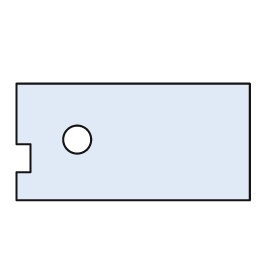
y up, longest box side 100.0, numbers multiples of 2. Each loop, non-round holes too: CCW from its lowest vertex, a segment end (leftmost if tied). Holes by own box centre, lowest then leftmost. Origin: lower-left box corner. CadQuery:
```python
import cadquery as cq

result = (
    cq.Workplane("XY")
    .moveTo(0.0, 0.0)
    .lineTo(100.0, 0.0)
    .lineTo(100.0, 50.0)
    .lineTo(0.0, 50.0)
    .lineTo(0.0, 24.0)
    .lineTo(6.0, 24.0)
    .lineTo(6.0, 12.0)
    .lineTo(0.0, 12.0)
    .close()
    .moveTo(26.0, 26.0)
    .circle(6.0)
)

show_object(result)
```